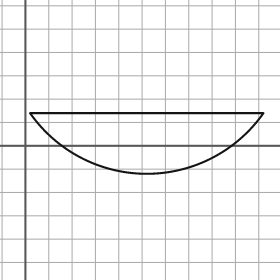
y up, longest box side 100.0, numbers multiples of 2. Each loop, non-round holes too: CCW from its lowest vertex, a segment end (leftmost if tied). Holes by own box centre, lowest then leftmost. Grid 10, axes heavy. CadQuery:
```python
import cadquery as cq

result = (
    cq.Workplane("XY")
    .moveTo(2.0, 14.0)
    .threePointArc((52.0, -12.0), (102.0, 14.0))
    .close()
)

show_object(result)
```